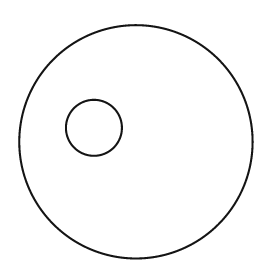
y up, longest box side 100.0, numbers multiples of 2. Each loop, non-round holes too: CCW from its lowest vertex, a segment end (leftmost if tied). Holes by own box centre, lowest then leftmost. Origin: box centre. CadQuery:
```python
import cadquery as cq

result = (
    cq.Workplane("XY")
    .moveTo(0.0, 0.0)
    .circle(50.0)
    .moveTo(-18.0, 6.0)
    .circle(12.0)
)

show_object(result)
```